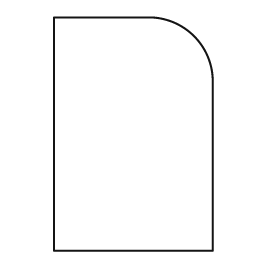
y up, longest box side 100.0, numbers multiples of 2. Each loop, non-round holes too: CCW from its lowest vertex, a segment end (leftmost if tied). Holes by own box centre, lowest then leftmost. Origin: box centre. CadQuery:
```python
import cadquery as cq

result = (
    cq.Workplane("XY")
    .moveTo(-34.0, -50.0)
    .lineTo(34.0, -50.0)
    .lineTo(34.0, 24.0)
    .threePointArc((26.0, 42.0), (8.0, 50.0))
    .lineTo(-34.0, 50.0)
    .close()
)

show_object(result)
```